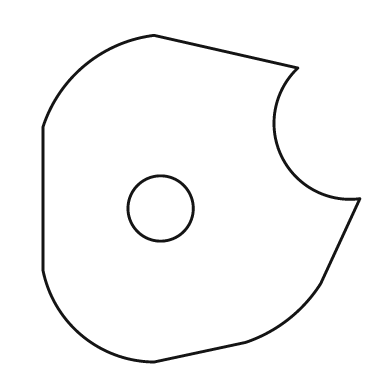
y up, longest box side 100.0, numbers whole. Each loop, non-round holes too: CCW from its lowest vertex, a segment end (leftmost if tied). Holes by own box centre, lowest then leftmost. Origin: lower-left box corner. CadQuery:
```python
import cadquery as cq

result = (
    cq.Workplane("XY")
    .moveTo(34.0, 0.0)
    .lineTo(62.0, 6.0)
    .threePointArc((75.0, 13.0), (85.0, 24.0))
    .lineTo(97.0, 50.0)
    .threePointArc((73.0, 63.0), (78.0, 90.0))
    .lineTo(34.0, 100.0)
    .threePointArc((13.0, 91.0), (0.0, 72.0))
    .lineTo(0.0, 28.0)
    .threePointArc((12.0, 8.0), (34.0, 0.0))
    .close()
    .moveTo(36.0, 47.0)
    .circle(10.0)
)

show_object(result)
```